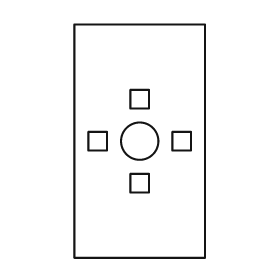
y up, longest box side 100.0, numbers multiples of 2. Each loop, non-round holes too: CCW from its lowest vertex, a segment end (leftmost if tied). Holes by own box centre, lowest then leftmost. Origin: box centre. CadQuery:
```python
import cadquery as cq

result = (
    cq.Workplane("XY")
    .moveTo(-28.0, -50.0)
    .lineTo(28.0, -50.0)
    .lineTo(28.0, 50.0)
    .lineTo(-28.0, 50.0)
    .close()
    .moveTo(-4.0, -22.0)
    .lineTo(4.0, -22.0)
    .lineTo(4.0, -14.0)
    .lineTo(-4.0, -14.0)
    .close()
    .moveTo(-22.0, -4.0)
    .lineTo(-14.0, -4.0)
    .lineTo(-14.0, 4.0)
    .lineTo(-22.0, 4.0)
    .close()
    .moveTo(0.0, 0.0)
    .circle(8.0)
    .moveTo(14.0, -4.0)
    .lineTo(22.0, -4.0)
    .lineTo(22.0, 4.0)
    .lineTo(14.0, 4.0)
    .close()
    .moveTo(-4.0, 14.0)
    .lineTo(4.0, 14.0)
    .lineTo(4.0, 22.0)
    .lineTo(-4.0, 22.0)
    .close()
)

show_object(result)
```